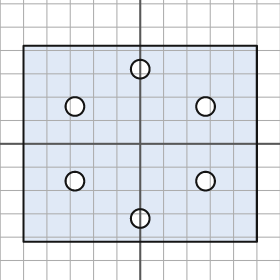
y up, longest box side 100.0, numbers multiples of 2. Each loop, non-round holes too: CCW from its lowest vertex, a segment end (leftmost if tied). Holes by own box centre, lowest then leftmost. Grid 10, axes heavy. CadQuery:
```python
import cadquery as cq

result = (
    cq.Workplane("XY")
    .moveTo(-50.0, -42.0)
    .lineTo(50.0, -42.0)
    .lineTo(50.0, 42.0)
    .lineTo(-50.0, 42.0)
    .close()
    .moveTo(0.0, -32.0)
    .circle(4.0)
    .moveTo(-28.0, -16.0)
    .circle(4.0)
    .moveTo(28.0, -16.0)
    .circle(4.0)
    .moveTo(-28.0, 16.0)
    .circle(4.0)
    .moveTo(28.0, 16.0)
    .circle(4.0)
    .moveTo(0.0, 32.0)
    .circle(4.0)
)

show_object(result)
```